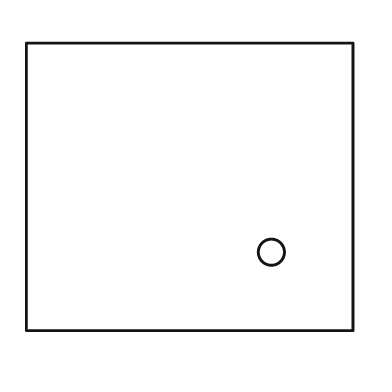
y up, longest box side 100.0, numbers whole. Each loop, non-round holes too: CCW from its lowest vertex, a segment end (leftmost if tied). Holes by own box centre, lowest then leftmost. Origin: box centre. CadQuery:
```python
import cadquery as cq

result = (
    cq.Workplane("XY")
    .moveTo(-50.0, -44.0)
    .lineTo(50.0, -44.0)
    .lineTo(50.0, 44.0)
    .lineTo(-50.0, 44.0)
    .close()
    .moveTo(25.0, -20.0)
    .circle(4.0)
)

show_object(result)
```